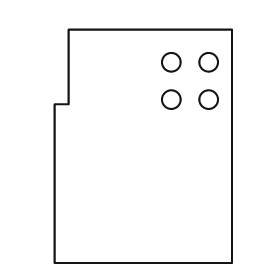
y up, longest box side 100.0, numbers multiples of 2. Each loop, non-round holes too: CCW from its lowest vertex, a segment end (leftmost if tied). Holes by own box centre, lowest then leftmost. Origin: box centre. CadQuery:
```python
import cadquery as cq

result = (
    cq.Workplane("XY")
    .moveTo(-38.0, -50.0)
    .lineTo(38.0, -50.0)
    .lineTo(38.0, 50.0)
    .lineTo(-32.0, 50.0)
    .lineTo(-32.0, 18.0)
    .lineTo(-38.0, 18.0)
    .close()
    .moveTo(12.0, 20.0)
    .circle(4.0)
    .moveTo(28.0, 20.0)
    .circle(4.0)
    .moveTo(12.0, 36.0)
    .circle(4.0)
    .moveTo(28.0, 36.0)
    .circle(4.0)
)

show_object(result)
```